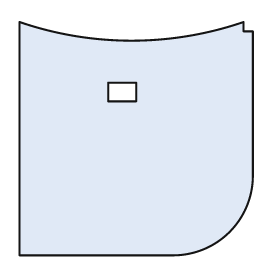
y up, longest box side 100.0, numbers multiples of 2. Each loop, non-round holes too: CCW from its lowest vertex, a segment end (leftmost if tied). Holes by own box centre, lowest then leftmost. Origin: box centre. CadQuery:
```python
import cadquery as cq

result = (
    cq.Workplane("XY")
    .moveTo(-50.0, -50.0)
    .lineTo(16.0, -50.0)
    .threePointArc((40.0, -40.0), (50.0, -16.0))
    .lineTo(50.0, 46.0)
    .lineTo(46.0, 46.0)
    .lineTo(46.0, 50.0)
    .threePointArc((-2.0, 42.0), (-50.0, 50.0))
    .close()
    .moveTo(-12.0, 16.0)
    .lineTo(0.0, 16.0)
    .lineTo(0.0, 24.0)
    .lineTo(-12.0, 24.0)
    .close()
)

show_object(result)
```